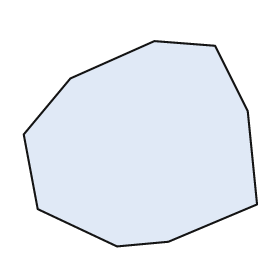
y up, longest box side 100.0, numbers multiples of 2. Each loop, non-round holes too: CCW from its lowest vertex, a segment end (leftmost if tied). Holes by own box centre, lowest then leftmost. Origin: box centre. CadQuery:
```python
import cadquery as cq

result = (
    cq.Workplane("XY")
    .moveTo(-10.0, -44.0)
    .lineTo(12.0, -42.0)
    .lineTo(50.0, -26.0)
    .lineTo(46.0, 14.0)
    .lineTo(32.0, 42.0)
    .lineTo(6.0, 44.0)
    .lineTo(-30.0, 28.0)
    .lineTo(-50.0, 4.0)
    .lineTo(-44.0, -28.0)
    .close()
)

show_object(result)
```